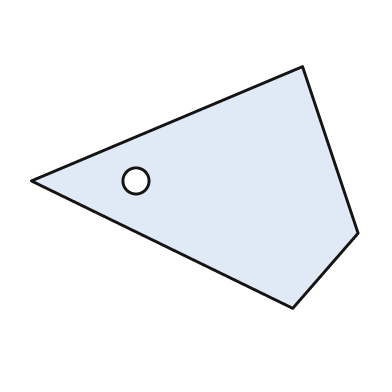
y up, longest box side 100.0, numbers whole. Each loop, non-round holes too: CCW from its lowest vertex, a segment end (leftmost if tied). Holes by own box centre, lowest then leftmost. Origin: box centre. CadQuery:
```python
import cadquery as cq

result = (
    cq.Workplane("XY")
    .moveTo(30.0, -37.0)
    .lineTo(50.0, -14.0)
    .lineTo(33.0, 37.0)
    .lineTo(-50.0, 2.0)
    .close()
    .moveTo(-18.0, 2.0)
    .circle(4.0)
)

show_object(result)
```